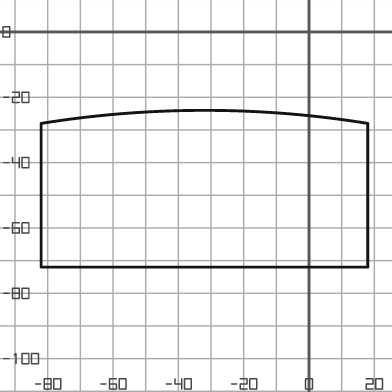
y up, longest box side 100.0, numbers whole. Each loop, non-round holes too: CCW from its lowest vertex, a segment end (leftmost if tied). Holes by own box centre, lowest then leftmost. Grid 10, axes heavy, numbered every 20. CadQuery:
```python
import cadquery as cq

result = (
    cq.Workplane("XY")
    .moveTo(-82.0, -72.0)
    .lineTo(18.0, -72.0)
    .lineTo(18.0, -28.0)
    .threePointArc((-32.0, -24.0), (-82.0, -28.0))
    .close()
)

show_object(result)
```